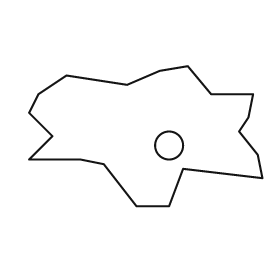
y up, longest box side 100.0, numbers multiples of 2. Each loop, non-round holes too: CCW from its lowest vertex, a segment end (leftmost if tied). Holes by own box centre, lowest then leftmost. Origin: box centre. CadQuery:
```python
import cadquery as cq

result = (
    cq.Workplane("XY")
    .moveTo(-4.0, -30.0)
    .lineTo(10.0, -30.0)
    .lineTo(16.0, -14.0)
    .lineTo(50.0, -18.0)
    .lineTo(48.0, -8.0)
    .lineTo(40.0, 2.0)
    .lineTo(44.0, 8.0)
    .lineTo(46.0, 18.0)
    .lineTo(28.0, 18.0)
    .lineTo(18.0, 30.0)
    .lineTo(6.0, 28.0)
    .lineTo(-8.0, 22.0)
    .lineTo(-34.0, 26.0)
    .lineTo(-46.0, 18.0)
    .lineTo(-50.0, 10.0)
    .lineTo(-40.0, 0.0)
    .lineTo(-50.0, -10.0)
    .lineTo(-28.0, -10.0)
    .lineTo(-18.0, -12.0)
    .close()
    .moveTo(10.0, -4.0)
    .circle(6.0)
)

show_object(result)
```